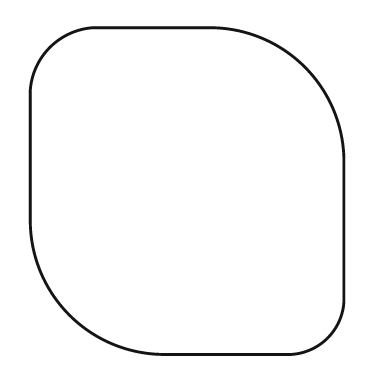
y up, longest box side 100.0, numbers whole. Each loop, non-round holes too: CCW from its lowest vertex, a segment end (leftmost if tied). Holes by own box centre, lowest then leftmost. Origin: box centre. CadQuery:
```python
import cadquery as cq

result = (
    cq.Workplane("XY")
    .moveTo(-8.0, -50.0)
    .lineTo(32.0, -50.0)
    .threePointArc((43.0, -45.0), (48.0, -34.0))
    .lineTo(48.0, 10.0)
    .threePointArc((36.0, 38.0), (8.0, 50.0))
    .lineTo(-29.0, 50.0)
    .threePointArc((-42.0, 44.0), (-48.0, 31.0))
    .lineTo(-48.0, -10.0)
    .threePointArc((-36.0, -38.0), (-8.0, -50.0))
    .close()
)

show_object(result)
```